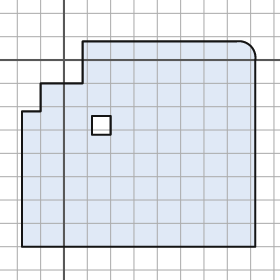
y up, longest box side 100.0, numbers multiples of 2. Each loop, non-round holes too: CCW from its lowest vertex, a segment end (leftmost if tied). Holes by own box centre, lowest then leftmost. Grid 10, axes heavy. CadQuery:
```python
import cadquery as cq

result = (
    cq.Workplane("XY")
    .moveTo(-18.0, -80.0)
    .lineTo(82.0, -80.0)
    .lineTo(82.0, 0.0)
    .threePointArc((80.0, 6.0), (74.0, 8.0))
    .lineTo(8.0, 8.0)
    .lineTo(8.0, -10.0)
    .lineTo(-10.0, -10.0)
    .lineTo(-10.0, -22.0)
    .lineTo(-18.0, -22.0)
    .close()
    .moveTo(12.0, -32.0)
    .lineTo(20.0, -32.0)
    .lineTo(20.0, -24.0)
    .lineTo(12.0, -24.0)
    .close()
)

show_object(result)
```